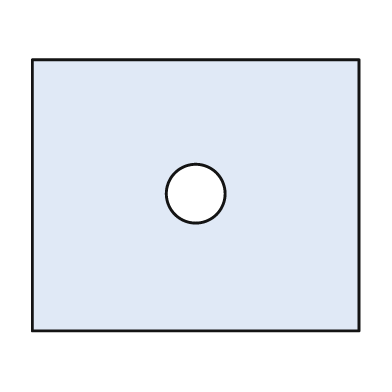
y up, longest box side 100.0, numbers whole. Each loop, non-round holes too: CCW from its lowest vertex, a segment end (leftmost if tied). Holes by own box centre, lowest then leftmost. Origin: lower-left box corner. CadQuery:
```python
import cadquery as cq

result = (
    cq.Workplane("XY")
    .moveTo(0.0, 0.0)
    .lineTo(100.0, 0.0)
    .lineTo(100.0, 83.0)
    .lineTo(0.0, 83.0)
    .close()
    .moveTo(50.0, 42.0)
    .circle(9.0)
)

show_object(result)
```